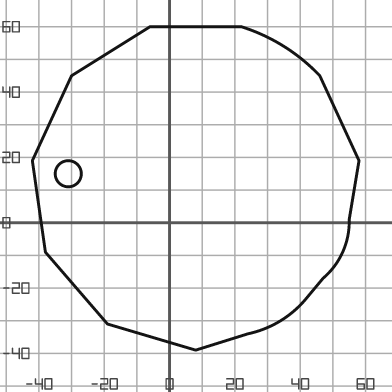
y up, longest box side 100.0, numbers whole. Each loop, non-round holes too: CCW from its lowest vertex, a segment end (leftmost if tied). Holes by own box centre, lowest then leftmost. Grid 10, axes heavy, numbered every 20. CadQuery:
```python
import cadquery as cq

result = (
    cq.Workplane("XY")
    .moveTo(8.0, -39.0)
    .lineTo(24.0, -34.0)
    .threePointArc((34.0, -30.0), (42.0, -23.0))
    .lineTo(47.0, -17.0)
    .threePointArc((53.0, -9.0), (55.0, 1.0))
    .lineTo(58.0, 19.0)
    .lineTo(46.0, 45.0)
    .threePointArc((35.0, 54.0), (22.0, 60.0))
    .lineTo(-6.0, 60.0)
    .lineTo(-30.0, 45.0)
    .lineTo(-42.0, 19.0)
    .lineTo(-38.0, -9.0)
    .lineTo(-19.0, -31.0)
    .close()
    .moveTo(-31.0, 15.0)
    .circle(4.0)
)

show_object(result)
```